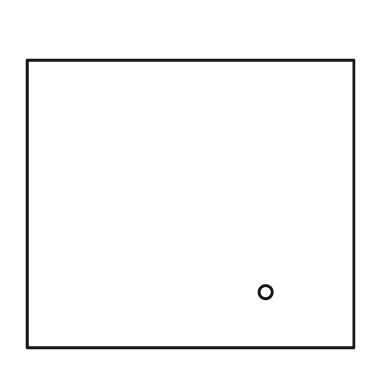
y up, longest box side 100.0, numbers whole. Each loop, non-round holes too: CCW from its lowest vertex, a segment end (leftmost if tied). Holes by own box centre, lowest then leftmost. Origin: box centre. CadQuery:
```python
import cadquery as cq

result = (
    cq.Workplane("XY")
    .moveTo(-50.0, -44.0)
    .lineTo(50.0, -44.0)
    .lineTo(50.0, 44.0)
    .lineTo(-50.0, 44.0)
    .close()
    .moveTo(23.0, -27.0)
    .circle(2.0)
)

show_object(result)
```